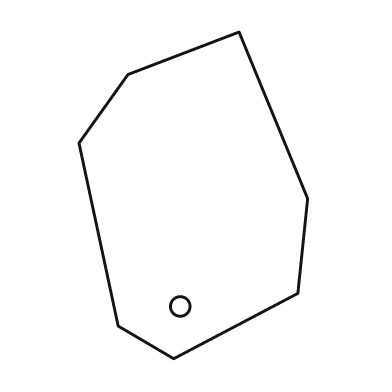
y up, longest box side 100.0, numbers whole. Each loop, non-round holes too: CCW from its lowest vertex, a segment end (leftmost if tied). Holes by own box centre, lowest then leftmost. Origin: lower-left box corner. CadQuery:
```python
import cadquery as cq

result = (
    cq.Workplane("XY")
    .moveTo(29.0, 0.0)
    .lineTo(67.0, 20.0)
    .lineTo(70.0, 49.0)
    .lineTo(49.0, 100.0)
    .lineTo(15.0, 87.0)
    .lineTo(0.0, 66.0)
    .lineTo(12.0, 10.0)
    .close()
    .moveTo(31.0, 16.0)
    .circle(3.0)
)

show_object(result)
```